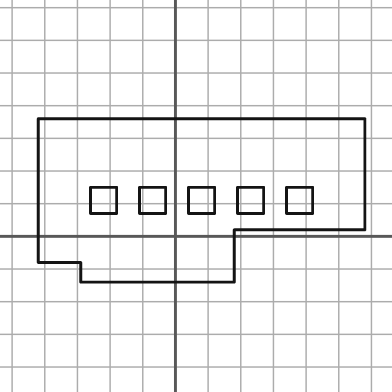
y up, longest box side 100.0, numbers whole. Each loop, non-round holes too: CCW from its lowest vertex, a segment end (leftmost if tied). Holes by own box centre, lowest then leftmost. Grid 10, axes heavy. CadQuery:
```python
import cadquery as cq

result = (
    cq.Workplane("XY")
    .moveTo(-29.0, -14.0)
    .lineTo(18.0, -14.0)
    .lineTo(18.0, 2.0)
    .lineTo(58.0, 2.0)
    .lineTo(58.0, 36.0)
    .lineTo(-42.0, 36.0)
    .lineTo(-42.0, -8.0)
    .lineTo(-29.0, -8.0)
    .close()
    .moveTo(-26.0, 7.0)
    .lineTo(-18.0, 7.0)
    .lineTo(-18.0, 15.0)
    .lineTo(-26.0, 15.0)
    .close()
    .moveTo(-11.0, 7.0)
    .lineTo(-3.0, 7.0)
    .lineTo(-3.0, 15.0)
    .lineTo(-11.0, 15.0)
    .close()
    .moveTo(4.0, 7.0)
    .lineTo(12.0, 7.0)
    .lineTo(12.0, 15.0)
    .lineTo(4.0, 15.0)
    .close()
    .moveTo(19.0, 7.0)
    .lineTo(27.0, 7.0)
    .lineTo(27.0, 15.0)
    .lineTo(19.0, 15.0)
    .close()
    .moveTo(34.0, 7.0)
    .lineTo(42.0, 7.0)
    .lineTo(42.0, 15.0)
    .lineTo(34.0, 15.0)
    .close()
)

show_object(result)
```